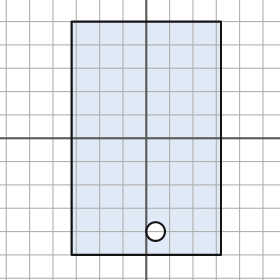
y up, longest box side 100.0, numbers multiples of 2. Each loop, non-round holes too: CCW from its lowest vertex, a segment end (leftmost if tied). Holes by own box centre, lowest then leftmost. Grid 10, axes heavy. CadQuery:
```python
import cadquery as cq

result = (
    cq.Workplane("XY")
    .moveTo(-32.0, -50.0)
    .lineTo(32.0, -50.0)
    .lineTo(32.0, 50.0)
    .lineTo(-32.0, 50.0)
    .close()
    .moveTo(4.0, -40.0)
    .circle(4.0)
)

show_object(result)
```